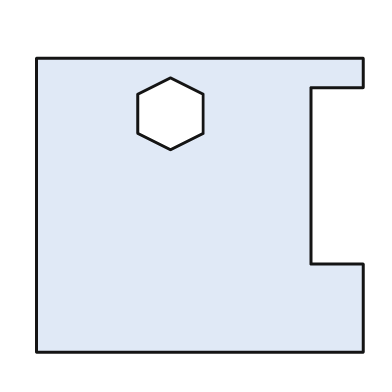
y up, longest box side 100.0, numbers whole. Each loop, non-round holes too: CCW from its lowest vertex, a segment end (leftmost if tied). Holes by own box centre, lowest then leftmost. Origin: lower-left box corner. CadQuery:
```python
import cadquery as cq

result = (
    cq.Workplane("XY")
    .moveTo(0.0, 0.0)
    .lineTo(100.0, 0.0)
    .lineTo(100.0, 27.0)
    .lineTo(84.0, 27.0)
    .lineTo(84.0, 81.0)
    .lineTo(100.0, 81.0)
    .lineTo(100.0, 90.0)
    .lineTo(0.0, 90.0)
    .close()
    .moveTo(41.0, 62.0)
    .lineTo(51.0, 67.0)
    .lineTo(51.0, 79.0)
    .lineTo(41.0, 84.0)
    .lineTo(31.0, 79.0)
    .lineTo(31.0, 67.0)
    .close()
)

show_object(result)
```